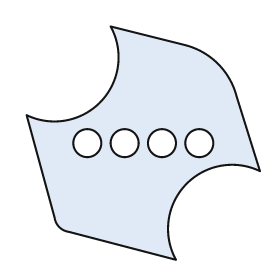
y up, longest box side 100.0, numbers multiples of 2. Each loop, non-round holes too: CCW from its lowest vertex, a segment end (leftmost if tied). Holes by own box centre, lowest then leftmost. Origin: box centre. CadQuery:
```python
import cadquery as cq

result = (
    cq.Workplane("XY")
    .moveTo(14.0, -50.0)
    .threePointArc((18.0, -18.0), (50.0, -12.0))
    .lineTo(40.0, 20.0)
    .threePointArc((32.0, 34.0), (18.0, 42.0))
    .lineTo(-14.0, 50.0)
    .threePointArc((-18.0, 18.0), (-50.0, 12.0))
    .lineTo(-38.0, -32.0)
    .threePointArc((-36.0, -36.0), (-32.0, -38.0))
    .close()
    .moveTo(-24.0, 0.0)
    .circle(6.0)
    .moveTo(-8.0, 0.0)
    .circle(6.0)
    .moveTo(8.0, 0.0)
    .circle(6.0)
    .moveTo(24.0, 0.0)
    .circle(6.0)
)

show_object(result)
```